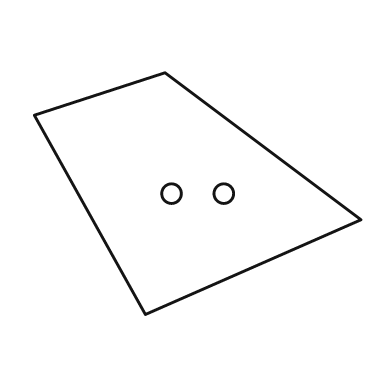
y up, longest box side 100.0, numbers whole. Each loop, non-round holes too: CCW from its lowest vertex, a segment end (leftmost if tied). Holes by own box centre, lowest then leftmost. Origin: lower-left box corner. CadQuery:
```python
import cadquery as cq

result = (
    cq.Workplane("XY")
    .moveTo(34.0, 0.0)
    .lineTo(100.0, 29.0)
    .lineTo(40.0, 74.0)
    .lineTo(0.0, 61.0)
    .close()
    .moveTo(42.0, 37.0)
    .circle(3.0)
    .moveTo(58.0, 37.0)
    .circle(3.0)
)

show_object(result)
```